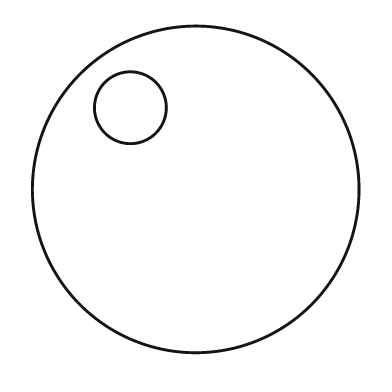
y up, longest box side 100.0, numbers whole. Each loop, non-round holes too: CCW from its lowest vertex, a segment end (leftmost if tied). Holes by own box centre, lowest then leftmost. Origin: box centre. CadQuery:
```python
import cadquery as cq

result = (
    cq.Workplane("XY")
    .moveTo(0.0, 0.0)
    .circle(50.0)
    .moveTo(-20.0, 25.0)
    .circle(11.0)
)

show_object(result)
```